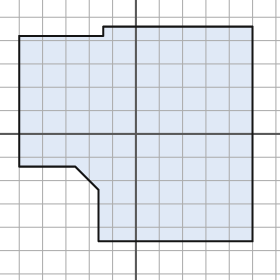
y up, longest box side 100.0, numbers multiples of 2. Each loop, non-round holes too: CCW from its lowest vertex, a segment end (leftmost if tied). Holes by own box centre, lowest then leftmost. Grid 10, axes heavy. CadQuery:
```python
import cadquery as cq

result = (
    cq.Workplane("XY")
    .moveTo(-16.0, -46.0)
    .lineTo(50.0, -46.0)
    .lineTo(50.0, 46.0)
    .lineTo(-14.0, 46.0)
    .lineTo(-14.0, 42.0)
    .lineTo(-50.0, 42.0)
    .lineTo(-50.0, -14.0)
    .lineTo(-26.0, -14.0)
    .lineTo(-16.0, -24.0)
    .close()
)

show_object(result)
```